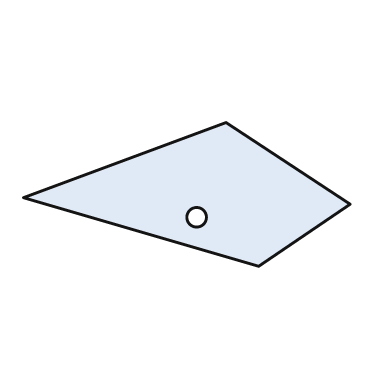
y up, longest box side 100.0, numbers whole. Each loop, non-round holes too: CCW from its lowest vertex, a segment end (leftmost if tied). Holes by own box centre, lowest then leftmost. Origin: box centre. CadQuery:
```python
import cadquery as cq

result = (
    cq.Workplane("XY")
    .moveTo(22.0, -22.0)
    .lineTo(50.0, -3.0)
    .lineTo(12.0, 22.0)
    .lineTo(-50.0, -1.0)
    .close()
    .moveTo(3.0, -7.0)
    .circle(3.0)
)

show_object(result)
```